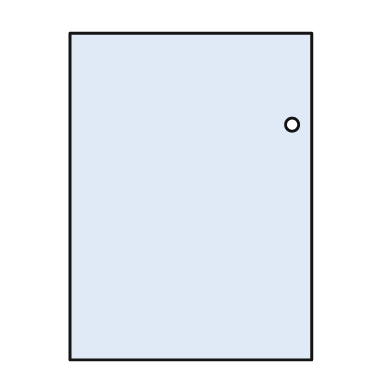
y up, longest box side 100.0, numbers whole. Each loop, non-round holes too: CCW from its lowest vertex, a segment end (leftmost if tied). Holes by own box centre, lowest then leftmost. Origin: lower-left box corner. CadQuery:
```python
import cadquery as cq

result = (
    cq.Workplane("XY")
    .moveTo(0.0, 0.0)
    .lineTo(74.0, 0.0)
    .lineTo(74.0, 100.0)
    .lineTo(0.0, 100.0)
    .close()
    .moveTo(68.0, 72.0)
    .circle(2.0)
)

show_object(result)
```